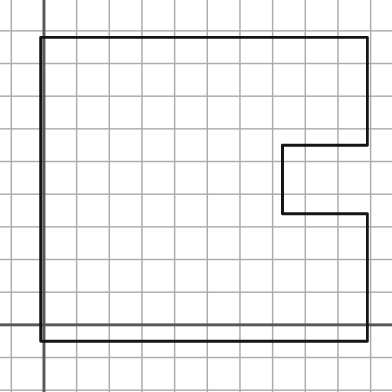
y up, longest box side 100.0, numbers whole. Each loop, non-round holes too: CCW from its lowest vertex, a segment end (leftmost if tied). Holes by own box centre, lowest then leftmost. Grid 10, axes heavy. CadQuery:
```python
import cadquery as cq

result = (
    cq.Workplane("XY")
    .moveTo(-1.0, -5.0)
    .lineTo(99.0, -5.0)
    .lineTo(99.0, 34.0)
    .lineTo(73.0, 34.0)
    .lineTo(73.0, 55.0)
    .lineTo(99.0, 55.0)
    .lineTo(99.0, 88.0)
    .lineTo(-1.0, 88.0)
    .close()
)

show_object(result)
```